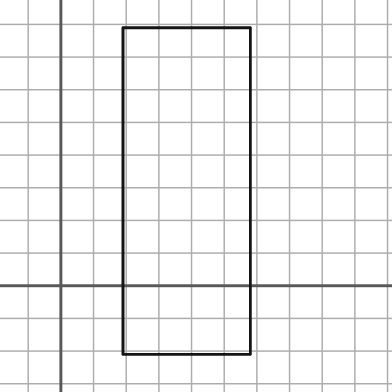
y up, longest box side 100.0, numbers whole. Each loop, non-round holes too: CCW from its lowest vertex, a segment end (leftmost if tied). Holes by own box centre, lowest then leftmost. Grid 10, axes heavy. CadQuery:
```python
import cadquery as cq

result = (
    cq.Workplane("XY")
    .moveTo(19.0, -21.0)
    .lineTo(58.0, -21.0)
    .lineTo(58.0, 79.0)
    .lineTo(19.0, 79.0)
    .close()
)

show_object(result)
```